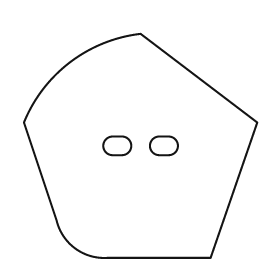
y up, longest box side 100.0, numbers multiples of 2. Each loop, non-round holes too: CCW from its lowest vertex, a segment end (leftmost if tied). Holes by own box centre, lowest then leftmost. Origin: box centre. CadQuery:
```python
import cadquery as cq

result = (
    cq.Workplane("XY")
    .moveTo(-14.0, -48.0)
    .lineTo(30.0, -48.0)
    .lineTo(50.0, 10.0)
    .lineTo(0.0, 48.0)
    .threePointArc((-30.0, 36.0), (-50.0, 10.0))
    .lineTo(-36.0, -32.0)
    .threePointArc((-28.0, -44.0), (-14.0, -48.0))
    .close()
    .moveTo(-12.0, -4.0)
    .lineTo(-8.0, -4.0)
    .threePointArc((-4.0, 0.0), (-8.0, 4.0))
    .lineTo(-12.0, 4.0)
    .threePointArc((-16.0, 0.0), (-12.0, -4.0))
    .close()
    .moveTo(8.0, -4.0)
    .lineTo(12.0, -4.0)
    .threePointArc((16.0, 0.0), (12.0, 4.0))
    .lineTo(8.0, 4.0)
    .threePointArc((4.0, 0.0), (8.0, -4.0))
    .close()
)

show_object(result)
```